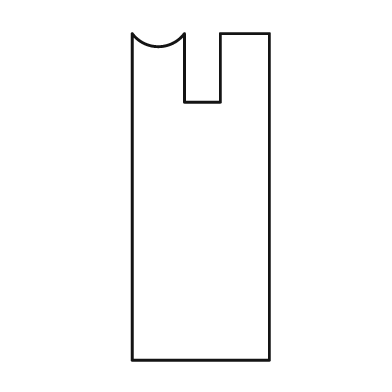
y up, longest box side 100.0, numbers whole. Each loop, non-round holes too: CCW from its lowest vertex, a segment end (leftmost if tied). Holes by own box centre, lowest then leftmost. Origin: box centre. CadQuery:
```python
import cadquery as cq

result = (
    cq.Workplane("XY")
    .moveTo(-21.0, -50.0)
    .lineTo(21.0, -50.0)
    .lineTo(21.0, 50.0)
    .lineTo(6.0, 50.0)
    .lineTo(6.0, 29.0)
    .lineTo(-5.0, 29.0)
    .lineTo(-5.0, 50.0)
    .threePointArc((-13.0, 46.0), (-21.0, 50.0))
    .close()
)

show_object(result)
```